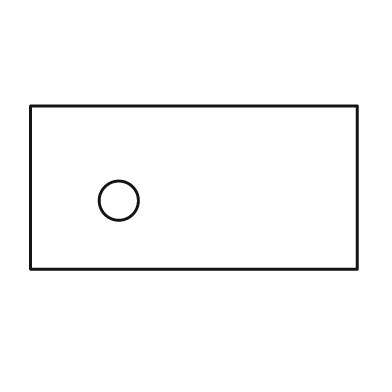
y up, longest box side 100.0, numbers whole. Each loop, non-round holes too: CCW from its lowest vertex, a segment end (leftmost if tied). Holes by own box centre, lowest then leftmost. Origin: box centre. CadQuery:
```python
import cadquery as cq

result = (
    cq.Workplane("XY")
    .moveTo(-50.0, -25.0)
    .lineTo(50.0, -25.0)
    .lineTo(50.0, 25.0)
    .lineTo(-50.0, 25.0)
    .close()
    .moveTo(-23.0, -4.0)
    .circle(6.0)
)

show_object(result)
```